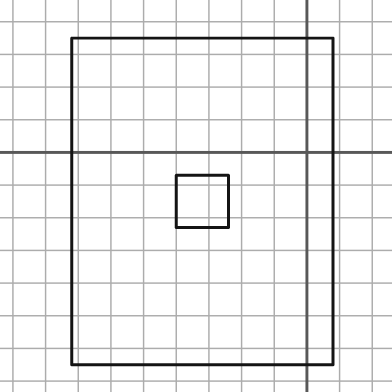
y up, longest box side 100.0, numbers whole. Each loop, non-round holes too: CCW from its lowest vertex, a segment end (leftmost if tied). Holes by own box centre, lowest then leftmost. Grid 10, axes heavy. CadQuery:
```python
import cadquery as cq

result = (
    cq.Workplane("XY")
    .moveTo(-72.0, -65.0)
    .lineTo(8.0, -65.0)
    .lineTo(8.0, 35.0)
    .lineTo(-72.0, 35.0)
    .close()
    .moveTo(-40.0, -23.0)
    .lineTo(-24.0, -23.0)
    .lineTo(-24.0, -7.0)
    .lineTo(-40.0, -7.0)
    .close()
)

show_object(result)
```